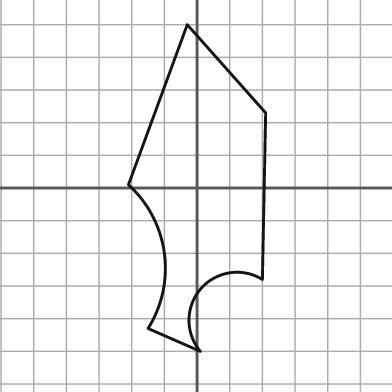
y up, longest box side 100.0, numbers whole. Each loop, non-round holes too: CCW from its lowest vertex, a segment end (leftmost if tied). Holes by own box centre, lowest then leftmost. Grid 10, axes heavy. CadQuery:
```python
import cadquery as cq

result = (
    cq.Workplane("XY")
    .moveTo(1.0, -50.0)
    .threePointArc((1.0, -31.0), (20.0, -28.0))
    .lineTo(21.0, 23.0)
    .lineTo(-3.0, 50.0)
    .lineTo(-21.0, 1.0)
    .threePointArc((-10.0, -20.0), (-15.0, -43.0))
    .close()
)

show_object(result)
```